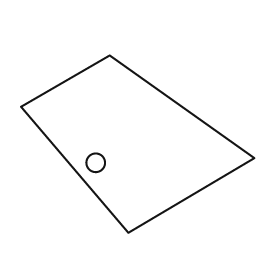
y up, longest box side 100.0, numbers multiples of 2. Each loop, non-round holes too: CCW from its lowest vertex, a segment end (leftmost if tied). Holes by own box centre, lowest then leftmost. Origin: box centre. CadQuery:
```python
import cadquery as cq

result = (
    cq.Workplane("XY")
    .moveTo(-4.0, -38.0)
    .lineTo(50.0, -6.0)
    .lineTo(-12.0, 38.0)
    .lineTo(-50.0, 16.0)
    .close()
    .moveTo(-18.0, -8.0)
    .circle(4.0)
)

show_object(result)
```